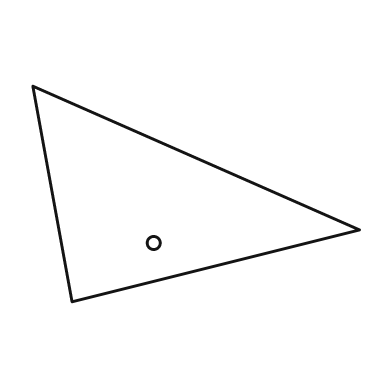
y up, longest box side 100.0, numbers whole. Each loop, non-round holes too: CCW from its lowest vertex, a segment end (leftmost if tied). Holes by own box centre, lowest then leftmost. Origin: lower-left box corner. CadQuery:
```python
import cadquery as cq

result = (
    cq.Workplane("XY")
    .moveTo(12.0, 0.0)
    .lineTo(100.0, 22.0)
    .lineTo(0.0, 66.0)
    .close()
    .moveTo(37.0, 18.0)
    .circle(2.0)
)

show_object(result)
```